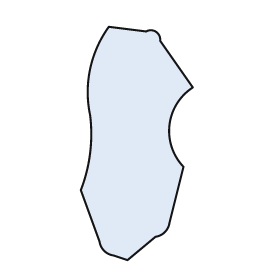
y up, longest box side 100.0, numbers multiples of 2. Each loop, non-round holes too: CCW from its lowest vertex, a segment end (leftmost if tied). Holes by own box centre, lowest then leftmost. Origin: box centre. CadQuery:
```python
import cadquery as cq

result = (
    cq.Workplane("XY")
    .moveTo(-4.0, -50.0)
    .lineTo(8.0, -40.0)
    .threePointArc((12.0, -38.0), (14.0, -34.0))
    .lineTo(20.0, -10.0)
    .threePointArc((14.0, 8.0), (24.0, 24.0))
    .lineTo(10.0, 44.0)
    .threePointArc((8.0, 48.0), (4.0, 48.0))
    .lineTo(-12.0, 50.0)
    .threePointArc((-20.0, 32.0), (-20.0, 12.0))
    .threePointArc((-20.0, -4.0), (-24.0, -20.0))
    .lineTo(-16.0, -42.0)
    .threePointArc((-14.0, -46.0), (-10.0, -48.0))
    .close()
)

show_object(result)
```